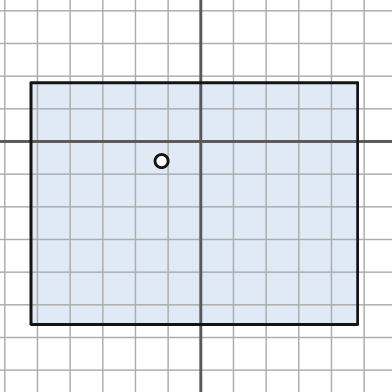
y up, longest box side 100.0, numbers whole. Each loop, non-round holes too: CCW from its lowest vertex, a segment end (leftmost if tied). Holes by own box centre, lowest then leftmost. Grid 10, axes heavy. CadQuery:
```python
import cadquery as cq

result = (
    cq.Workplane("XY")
    .moveTo(-52.0, -56.0)
    .lineTo(48.0, -56.0)
    .lineTo(48.0, 18.0)
    .lineTo(-52.0, 18.0)
    .close()
    .moveTo(-12.0, -6.0)
    .circle(2.0)
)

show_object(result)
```